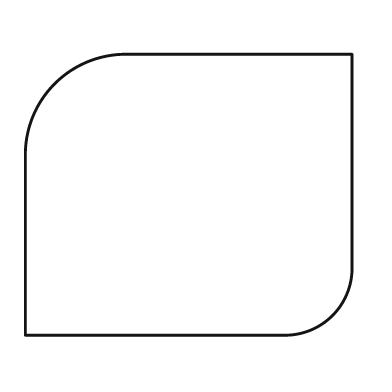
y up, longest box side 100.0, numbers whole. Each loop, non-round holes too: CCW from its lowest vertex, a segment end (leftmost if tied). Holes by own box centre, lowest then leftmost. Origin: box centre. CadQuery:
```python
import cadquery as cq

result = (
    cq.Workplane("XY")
    .moveTo(-50.0, -43.0)
    .lineTo(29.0, -43.0)
    .threePointArc((44.0, -37.0), (50.0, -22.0))
    .lineTo(50.0, 43.0)
    .lineTo(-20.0, 43.0)
    .threePointArc((-41.0, 34.0), (-50.0, 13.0))
    .close()
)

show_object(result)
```